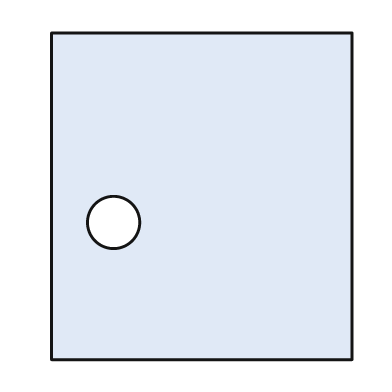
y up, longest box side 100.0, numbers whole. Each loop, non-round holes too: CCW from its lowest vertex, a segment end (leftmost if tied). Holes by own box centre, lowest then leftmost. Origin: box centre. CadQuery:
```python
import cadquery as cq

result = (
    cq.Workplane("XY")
    .moveTo(-46.0, -50.0)
    .lineTo(46.0, -50.0)
    .lineTo(46.0, 50.0)
    .lineTo(-46.0, 50.0)
    .close()
    .moveTo(-27.0, -8.0)
    .circle(8.0)
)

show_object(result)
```